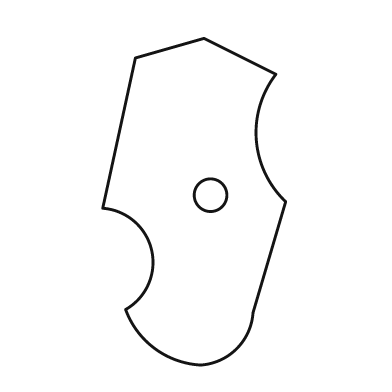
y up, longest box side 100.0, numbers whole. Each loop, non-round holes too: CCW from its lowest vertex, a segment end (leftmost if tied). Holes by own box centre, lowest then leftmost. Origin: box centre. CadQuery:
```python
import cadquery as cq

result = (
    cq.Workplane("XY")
    .moveTo(2.0, -50.0)
    .threePointArc((13.0, -45.0), (18.0, -34.0))
    .lineTo(28.0, 0.0)
    .threePointArc((19.0, 19.0), (25.0, 39.0))
    .lineTo(3.0, 50.0)
    .lineTo(-18.0, 44.0)
    .lineTo(-28.0, -2.0)
    .threePointArc((-13.0, -15.0), (-21.0, -33.0))
    .threePointArc((-12.0, -45.0), (2.0, -50.0))
    .close()
    .moveTo(5.0, 2.0)
    .circle(5.0)
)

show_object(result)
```